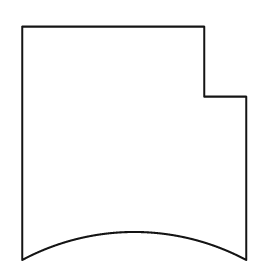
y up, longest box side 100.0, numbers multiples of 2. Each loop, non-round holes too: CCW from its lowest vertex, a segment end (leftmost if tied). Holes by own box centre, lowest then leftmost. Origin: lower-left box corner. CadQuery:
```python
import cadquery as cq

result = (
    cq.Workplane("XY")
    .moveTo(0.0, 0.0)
    .threePointArc((48.0, 12.0), (96.0, 0.0))
    .lineTo(96.0, 70.0)
    .lineTo(78.0, 70.0)
    .lineTo(78.0, 100.0)
    .lineTo(0.0, 100.0)
    .close()
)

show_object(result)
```